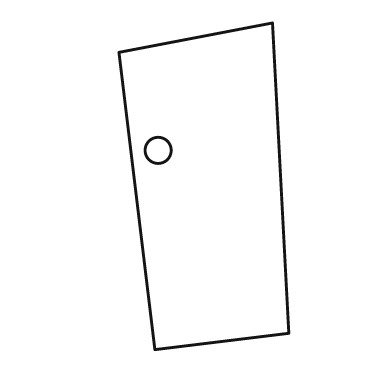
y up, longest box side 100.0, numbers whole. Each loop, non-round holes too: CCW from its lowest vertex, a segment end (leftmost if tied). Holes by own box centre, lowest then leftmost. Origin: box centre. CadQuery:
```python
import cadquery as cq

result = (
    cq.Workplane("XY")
    .moveTo(-15.0, -50.0)
    .lineTo(26.0, -45.0)
    .lineTo(21.0, 50.0)
    .lineTo(-26.0, 41.0)
    .close()
    .moveTo(-14.0, 11.0)
    .circle(4.0)
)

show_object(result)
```